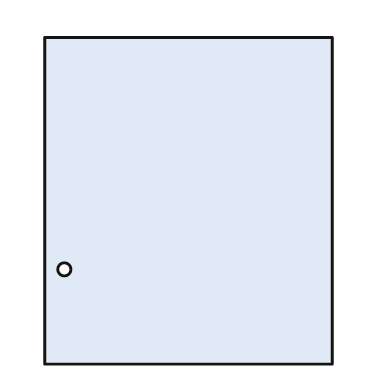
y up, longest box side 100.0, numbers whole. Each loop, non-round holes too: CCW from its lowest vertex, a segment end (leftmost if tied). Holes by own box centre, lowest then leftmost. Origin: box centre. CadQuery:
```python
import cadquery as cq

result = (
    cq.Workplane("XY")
    .moveTo(-44.0, -50.0)
    .lineTo(44.0, -50.0)
    .lineTo(44.0, 50.0)
    .lineTo(-44.0, 50.0)
    .close()
    .moveTo(-38.0, -21.0)
    .circle(2.0)
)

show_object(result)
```